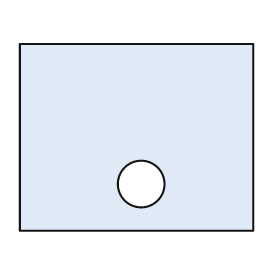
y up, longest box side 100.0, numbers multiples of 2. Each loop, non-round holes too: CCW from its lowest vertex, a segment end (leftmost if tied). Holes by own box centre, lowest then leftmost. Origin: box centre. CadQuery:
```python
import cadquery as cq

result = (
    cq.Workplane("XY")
    .moveTo(-50.0, -40.0)
    .lineTo(50.0, -40.0)
    .lineTo(50.0, 40.0)
    .lineTo(-50.0, 40.0)
    .close()
    .moveTo(2.0, -20.0)
    .circle(10.0)
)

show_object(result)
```